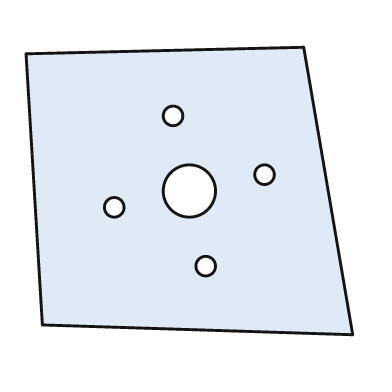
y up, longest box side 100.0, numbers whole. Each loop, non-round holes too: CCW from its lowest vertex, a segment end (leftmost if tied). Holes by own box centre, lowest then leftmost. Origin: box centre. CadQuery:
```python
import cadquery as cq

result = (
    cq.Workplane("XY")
    .moveTo(50.0, -44.0)
    .lineTo(35.0, 44.0)
    .lineTo(-50.0, 42.0)
    .lineTo(-45.0, -41.0)
    .close()
    .moveTo(5.0, -23.0)
    .circle(3.0)
    .moveTo(-23.0, -5.0)
    .circle(3.0)
    .moveTo(0.0, 0.0)
    .circle(8.0)
    .moveTo(23.0, 5.0)
    .circle(3.0)
    .moveTo(-5.0, 23.0)
    .circle(3.0)
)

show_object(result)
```